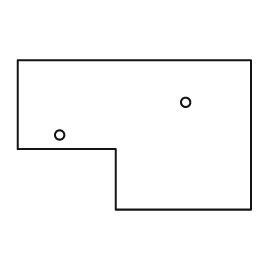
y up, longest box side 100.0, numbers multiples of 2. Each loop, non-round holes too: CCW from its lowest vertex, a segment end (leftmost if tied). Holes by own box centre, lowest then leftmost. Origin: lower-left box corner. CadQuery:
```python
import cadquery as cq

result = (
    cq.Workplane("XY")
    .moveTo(42.0, 0.0)
    .lineTo(100.0, 0.0)
    .lineTo(100.0, 64.0)
    .lineTo(0.0, 64.0)
    .lineTo(0.0, 26.0)
    .lineTo(42.0, 26.0)
    .close()
    .moveTo(18.0, 32.0)
    .circle(2.0)
    .moveTo(72.0, 46.0)
    .circle(2.0)
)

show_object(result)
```